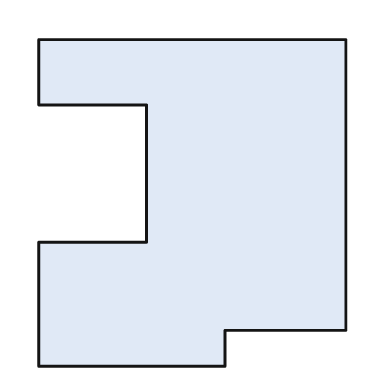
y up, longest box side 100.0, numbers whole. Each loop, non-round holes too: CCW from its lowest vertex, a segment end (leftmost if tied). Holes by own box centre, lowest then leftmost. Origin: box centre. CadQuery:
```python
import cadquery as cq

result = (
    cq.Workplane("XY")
    .moveTo(-47.0, -50.0)
    .lineTo(10.0, -50.0)
    .lineTo(10.0, -39.0)
    .lineTo(47.0, -39.0)
    .lineTo(47.0, 50.0)
    .lineTo(-47.0, 50.0)
    .lineTo(-47.0, 30.0)
    .lineTo(-14.0, 30.0)
    .lineTo(-14.0, -12.0)
    .lineTo(-47.0, -12.0)
    .close()
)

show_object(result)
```